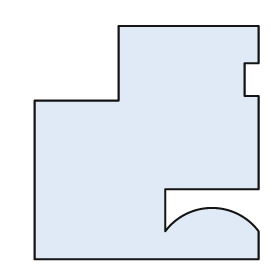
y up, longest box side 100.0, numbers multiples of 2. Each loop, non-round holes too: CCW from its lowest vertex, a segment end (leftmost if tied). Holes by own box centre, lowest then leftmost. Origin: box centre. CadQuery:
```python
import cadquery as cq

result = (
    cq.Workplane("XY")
    .moveTo(-48.0, -50.0)
    .lineTo(48.0, -50.0)
    .lineTo(48.0, -38.0)
    .threePointArc((28.0, -28.0), (8.0, -38.0))
    .lineTo(8.0, -20.0)
    .lineTo(48.0, -20.0)
    .lineTo(48.0, 20.0)
    .lineTo(42.0, 20.0)
    .lineTo(42.0, 34.0)
    .lineTo(48.0, 34.0)
    .lineTo(48.0, 50.0)
    .lineTo(-12.0, 50.0)
    .lineTo(-12.0, 18.0)
    .lineTo(-48.0, 18.0)
    .close()
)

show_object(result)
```